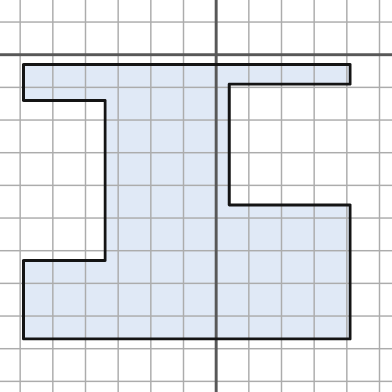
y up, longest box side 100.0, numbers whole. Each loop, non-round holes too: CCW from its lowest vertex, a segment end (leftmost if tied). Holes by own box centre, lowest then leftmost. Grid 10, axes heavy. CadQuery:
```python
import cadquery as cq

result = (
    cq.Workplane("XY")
    .moveTo(-59.0, -87.0)
    .lineTo(41.0, -87.0)
    .lineTo(41.0, -46.0)
    .lineTo(4.0, -46.0)
    .lineTo(4.0, -9.0)
    .lineTo(41.0, -9.0)
    .lineTo(41.0, -3.0)
    .lineTo(-59.0, -3.0)
    .lineTo(-59.0, -14.0)
    .lineTo(-34.0, -14.0)
    .lineTo(-34.0, -63.0)
    .lineTo(-59.0, -63.0)
    .close()
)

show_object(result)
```